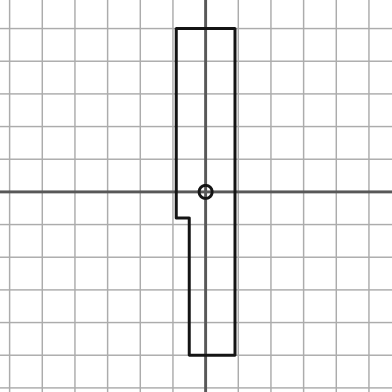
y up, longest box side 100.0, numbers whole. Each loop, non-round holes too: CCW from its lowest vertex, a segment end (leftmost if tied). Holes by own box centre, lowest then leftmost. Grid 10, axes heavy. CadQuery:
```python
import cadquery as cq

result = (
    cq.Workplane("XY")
    .moveTo(-5.0, -50.0)
    .lineTo(9.0, -50.0)
    .lineTo(9.0, 50.0)
    .lineTo(-9.0, 50.0)
    .lineTo(-9.0, -8.0)
    .lineTo(-5.0, -8.0)
    .close()
    .moveTo(0.0, 0.0)
    .circle(2.0)
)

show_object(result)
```